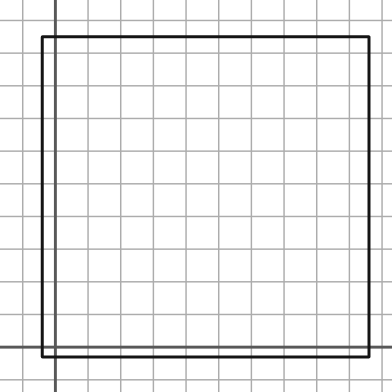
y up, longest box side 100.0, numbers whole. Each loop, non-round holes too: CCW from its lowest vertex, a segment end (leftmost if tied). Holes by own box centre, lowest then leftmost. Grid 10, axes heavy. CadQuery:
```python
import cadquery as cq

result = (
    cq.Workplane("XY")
    .moveTo(-4.0, -3.0)
    .lineTo(96.0, -3.0)
    .lineTo(96.0, 95.0)
    .lineTo(-4.0, 95.0)
    .close()
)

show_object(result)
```